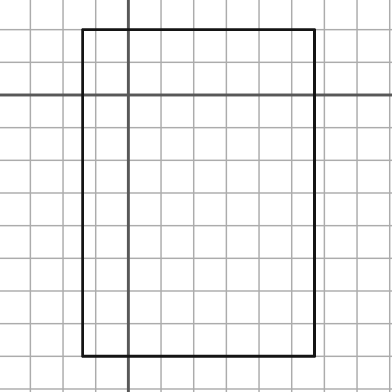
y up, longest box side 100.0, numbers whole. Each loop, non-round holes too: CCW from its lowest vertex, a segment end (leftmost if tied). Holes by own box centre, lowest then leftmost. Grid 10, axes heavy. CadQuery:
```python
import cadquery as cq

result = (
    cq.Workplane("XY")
    .moveTo(-14.0, -80.0)
    .lineTo(57.0, -80.0)
    .lineTo(57.0, 20.0)
    .lineTo(-14.0, 20.0)
    .close()
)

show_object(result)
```